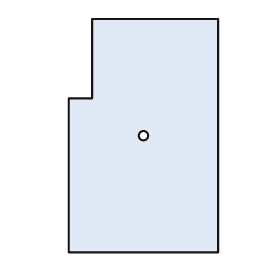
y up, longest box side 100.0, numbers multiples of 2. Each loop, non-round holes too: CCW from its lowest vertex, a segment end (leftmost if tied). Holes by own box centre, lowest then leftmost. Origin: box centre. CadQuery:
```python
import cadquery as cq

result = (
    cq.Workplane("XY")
    .moveTo(-32.0, -50.0)
    .lineTo(32.0, -50.0)
    .lineTo(32.0, 50.0)
    .lineTo(-22.0, 50.0)
    .lineTo(-22.0, 16.0)
    .lineTo(-32.0, 16.0)
    .close()
    .moveTo(0.0, 0.0)
    .circle(2.0)
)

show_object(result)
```